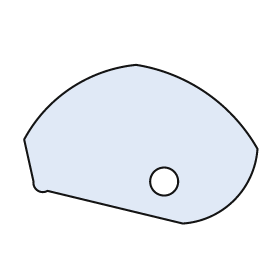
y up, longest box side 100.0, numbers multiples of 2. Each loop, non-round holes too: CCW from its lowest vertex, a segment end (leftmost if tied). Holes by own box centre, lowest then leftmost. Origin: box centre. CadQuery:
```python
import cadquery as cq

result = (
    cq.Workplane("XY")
    .moveTo(18.0, -34.0)
    .threePointArc((40.0, -24.0), (50.0, -2.0))
    .threePointArc((28.0, 22.0), (-2.0, 34.0))
    .threePointArc((-30.0, 24.0), (-50.0, 2.0))
    .lineTo(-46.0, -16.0)
    .threePointArc((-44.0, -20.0), (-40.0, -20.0))
    .close()
    .moveTo(10.0, -16.0)
    .circle(6.0)
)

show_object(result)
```